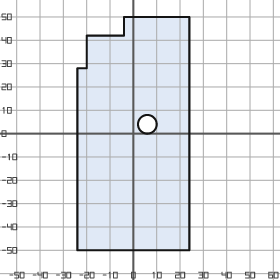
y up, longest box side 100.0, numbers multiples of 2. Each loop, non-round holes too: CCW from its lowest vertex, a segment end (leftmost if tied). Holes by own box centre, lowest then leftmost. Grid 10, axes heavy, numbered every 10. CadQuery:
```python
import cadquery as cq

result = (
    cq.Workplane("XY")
    .moveTo(-24.0, -50.0)
    .lineTo(24.0, -50.0)
    .lineTo(24.0, 50.0)
    .lineTo(-4.0, 50.0)
    .lineTo(-4.0, 42.0)
    .lineTo(-20.0, 42.0)
    .lineTo(-20.0, 28.0)
    .lineTo(-24.0, 28.0)
    .close()
    .moveTo(6.0, 4.0)
    .circle(4.0)
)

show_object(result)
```